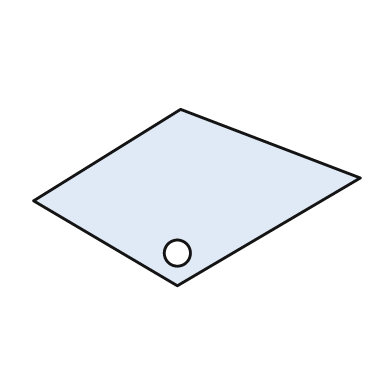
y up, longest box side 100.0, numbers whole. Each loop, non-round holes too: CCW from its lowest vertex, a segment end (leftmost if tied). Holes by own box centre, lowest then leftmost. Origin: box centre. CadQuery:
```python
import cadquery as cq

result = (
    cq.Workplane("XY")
    .moveTo(-6.0, -27.0)
    .lineTo(50.0, 6.0)
    .lineTo(-5.0, 27.0)
    .lineTo(-50.0, -1.0)
    .close()
    .moveTo(-6.0, -17.0)
    .circle(4.0)
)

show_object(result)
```